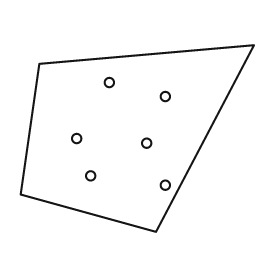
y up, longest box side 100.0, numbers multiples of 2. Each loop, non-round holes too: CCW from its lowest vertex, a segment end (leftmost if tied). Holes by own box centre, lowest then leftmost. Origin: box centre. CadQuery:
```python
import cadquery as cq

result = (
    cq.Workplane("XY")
    .moveTo(8.0, -40.0)
    .lineTo(50.0, 40.0)
    .lineTo(-42.0, 32.0)
    .lineTo(-50.0, -24.0)
    .close()
    .moveTo(12.0, -20.0)
    .circle(2.0)
    .moveTo(-20.0, -16.0)
    .circle(2.0)
    .moveTo(4.0, -2.0)
    .circle(2.0)
    .moveTo(-26.0, 0.0)
    .circle(2.0)
    .moveTo(12.0, 18.0)
    .circle(2.0)
    .moveTo(-12.0, 24.0)
    .circle(2.0)
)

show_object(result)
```